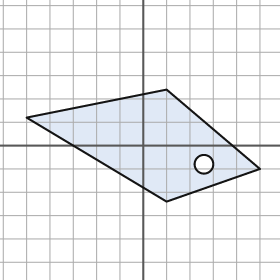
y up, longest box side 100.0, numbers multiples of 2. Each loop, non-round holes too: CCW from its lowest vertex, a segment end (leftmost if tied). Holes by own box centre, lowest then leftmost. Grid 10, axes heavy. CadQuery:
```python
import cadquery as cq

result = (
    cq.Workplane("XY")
    .moveTo(10.0, -24.0)
    .lineTo(50.0, -10.0)
    .lineTo(10.0, 24.0)
    .lineTo(-50.0, 12.0)
    .close()
    .moveTo(26.0, -8.0)
    .circle(4.0)
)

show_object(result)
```